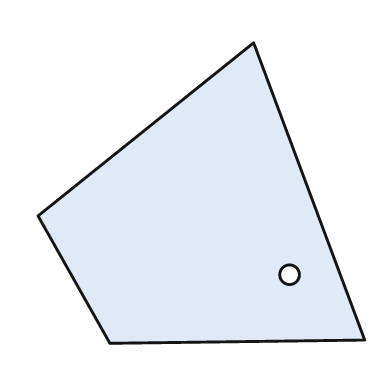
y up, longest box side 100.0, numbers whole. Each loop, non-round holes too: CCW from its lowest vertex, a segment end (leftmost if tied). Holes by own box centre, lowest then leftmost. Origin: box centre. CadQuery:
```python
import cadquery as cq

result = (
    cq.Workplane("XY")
    .moveTo(-28.0, -46.0)
    .lineTo(50.0, -45.0)
    .lineTo(16.0, 46.0)
    .lineTo(-50.0, -7.0)
    .close()
    .moveTo(27.0, -25.0)
    .circle(3.0)
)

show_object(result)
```